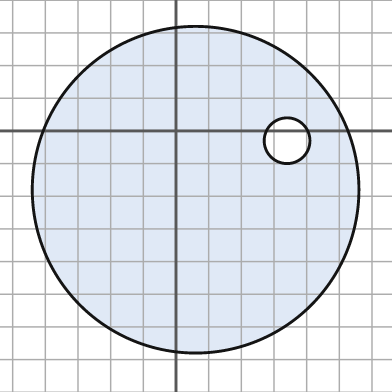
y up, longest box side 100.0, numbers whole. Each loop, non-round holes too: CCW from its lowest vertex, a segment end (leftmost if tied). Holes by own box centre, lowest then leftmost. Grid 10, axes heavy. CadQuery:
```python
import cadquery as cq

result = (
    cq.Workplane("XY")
    .moveTo(6.0, -18.0)
    .circle(50.0)
    .moveTo(34.0, -3.0)
    .circle(7.0)
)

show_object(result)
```